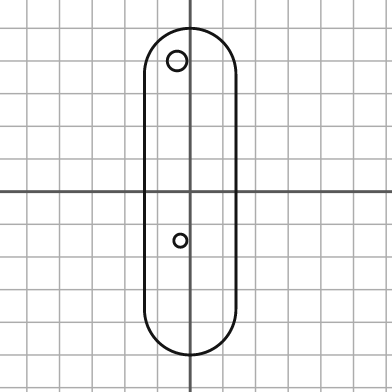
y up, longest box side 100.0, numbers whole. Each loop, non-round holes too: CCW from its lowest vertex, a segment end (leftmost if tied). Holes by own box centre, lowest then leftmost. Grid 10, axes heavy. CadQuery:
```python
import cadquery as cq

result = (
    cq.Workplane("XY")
    .moveTo(-14.0, -36.0)
    .threePointArc((0.0, -50.0), (14.0, -36.0))
    .lineTo(14.0, 36.0)
    .threePointArc((0.0, 50.0), (-14.0, 36.0))
    .close()
    .moveTo(-3.0, -15.0)
    .circle(2.0)
    .moveTo(-4.0, 40.0)
    .circle(3.0)
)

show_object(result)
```